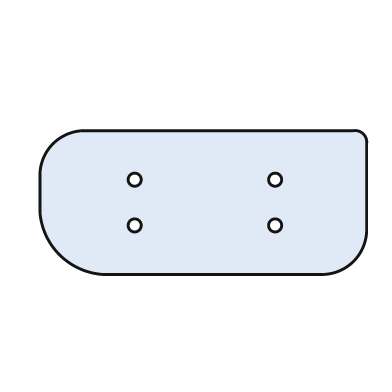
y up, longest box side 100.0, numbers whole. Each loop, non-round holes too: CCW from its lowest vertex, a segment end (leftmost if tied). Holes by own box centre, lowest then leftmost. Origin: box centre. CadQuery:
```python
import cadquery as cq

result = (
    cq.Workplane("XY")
    .moveTo(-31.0, -22.0)
    .lineTo(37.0, -22.0)
    .threePointArc((46.0, -18.0), (50.0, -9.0))
    .lineTo(50.0, 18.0)
    .threePointArc((49.0, 21.0), (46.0, 22.0))
    .lineTo(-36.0, 22.0)
    .threePointArc((-46.0, 18.0), (-50.0, 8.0))
    .lineTo(-50.0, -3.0)
    .threePointArc((-44.0, -16.0), (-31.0, -22.0))
    .close()
    .moveTo(-21.0, -7.0)
    .circle(2.0)
    .moveTo(22.0, -7.0)
    .circle(2.0)
    .moveTo(-21.0, 7.0)
    .circle(2.0)
    .moveTo(22.0, 7.0)
    .circle(2.0)
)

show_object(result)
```